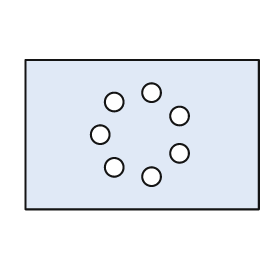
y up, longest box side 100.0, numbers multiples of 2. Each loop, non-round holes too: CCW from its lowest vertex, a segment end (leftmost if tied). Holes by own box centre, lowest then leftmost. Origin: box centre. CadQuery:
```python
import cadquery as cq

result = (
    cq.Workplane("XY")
    .moveTo(-50.0, -32.0)
    .lineTo(50.0, -32.0)
    .lineTo(50.0, 32.0)
    .lineTo(-50.0, 32.0)
    .close()
    .moveTo(4.0, -18.0)
    .circle(4.0)
    .moveTo(-12.0, -14.0)
    .circle(4.0)
    .moveTo(16.0, -8.0)
    .circle(4.0)
    .moveTo(-18.0, 0.0)
    .circle(4.0)
    .moveTo(16.0, 8.0)
    .circle(4.0)
    .moveTo(-12.0, 14.0)
    .circle(4.0)
    .moveTo(4.0, 18.0)
    .circle(4.0)
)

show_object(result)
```